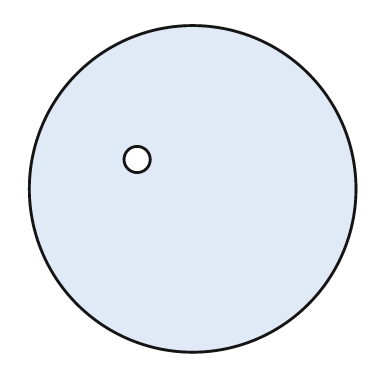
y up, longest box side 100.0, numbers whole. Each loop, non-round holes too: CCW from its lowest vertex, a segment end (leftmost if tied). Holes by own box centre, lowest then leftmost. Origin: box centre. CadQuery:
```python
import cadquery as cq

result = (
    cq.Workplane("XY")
    .moveTo(0.0, 0.0)
    .circle(50.0)
    .moveTo(-17.0, 9.0)
    .circle(4.0)
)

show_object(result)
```